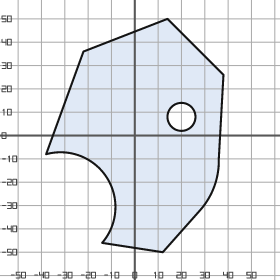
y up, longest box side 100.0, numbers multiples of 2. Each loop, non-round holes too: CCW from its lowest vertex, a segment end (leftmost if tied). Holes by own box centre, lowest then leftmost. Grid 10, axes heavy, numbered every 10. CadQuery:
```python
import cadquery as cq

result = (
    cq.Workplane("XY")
    .moveTo(12.0, -50.0)
    .lineTo(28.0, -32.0)
    .threePointArc((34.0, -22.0), (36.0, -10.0))
    .lineTo(38.0, 26.0)
    .lineTo(14.0, 50.0)
    .lineTo(-22.0, 36.0)
    .lineTo(-38.0, -8.0)
    .threePointArc((-12.0, -18.0), (-14.0, -46.0))
    .close()
    .moveTo(20.0, 8.0)
    .circle(6.0)
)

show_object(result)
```